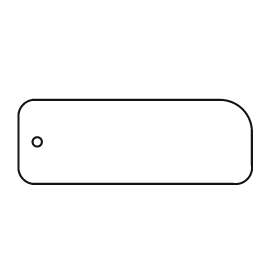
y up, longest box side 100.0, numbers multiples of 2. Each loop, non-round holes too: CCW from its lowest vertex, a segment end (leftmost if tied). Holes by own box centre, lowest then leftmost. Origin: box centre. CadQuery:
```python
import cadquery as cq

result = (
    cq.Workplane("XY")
    .moveTo(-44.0, -18.0)
    .lineTo(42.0, -18.0)
    .threePointArc((48.0, -16.0), (50.0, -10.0))
    .lineTo(50.0, 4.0)
    .threePointArc((46.0, 14.0), (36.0, 18.0))
    .lineTo(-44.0, 18.0)
    .threePointArc((-48.0, 16.0), (-50.0, 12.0))
    .lineTo(-50.0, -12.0)
    .threePointArc((-48.0, -16.0), (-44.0, -18.0))
    .close()
    .moveTo(-42.0, 0.0)
    .circle(2.0)
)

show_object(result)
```